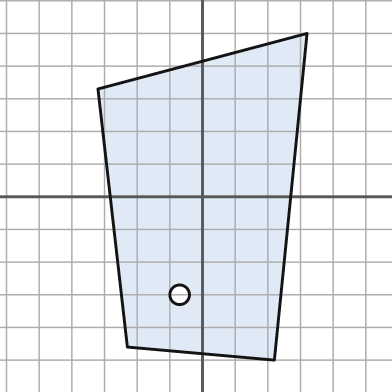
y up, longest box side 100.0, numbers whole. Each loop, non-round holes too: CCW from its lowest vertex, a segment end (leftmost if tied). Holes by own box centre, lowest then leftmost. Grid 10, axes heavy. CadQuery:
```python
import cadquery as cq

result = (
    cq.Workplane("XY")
    .moveTo(22.0, -50.0)
    .lineTo(32.0, 50.0)
    .lineTo(-32.0, 33.0)
    .lineTo(-23.0, -46.0)
    .close()
    .moveTo(-7.0, -30.0)
    .circle(3.0)
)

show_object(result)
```